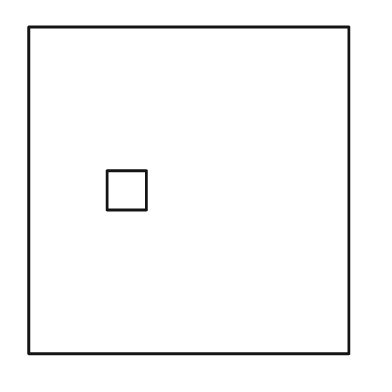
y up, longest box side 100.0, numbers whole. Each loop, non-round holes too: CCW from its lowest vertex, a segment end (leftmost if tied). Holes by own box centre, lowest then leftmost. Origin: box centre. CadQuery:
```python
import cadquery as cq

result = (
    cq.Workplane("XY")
    .moveTo(-49.0, -50.0)
    .lineTo(49.0, -50.0)
    .lineTo(49.0, 50.0)
    .lineTo(-49.0, 50.0)
    .close()
    .moveTo(-25.0, -6.0)
    .lineTo(-13.0, -6.0)
    .lineTo(-13.0, 6.0)
    .lineTo(-25.0, 6.0)
    .close()
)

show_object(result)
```